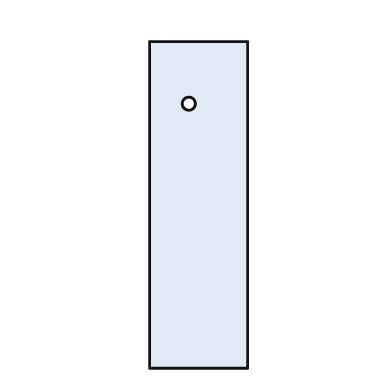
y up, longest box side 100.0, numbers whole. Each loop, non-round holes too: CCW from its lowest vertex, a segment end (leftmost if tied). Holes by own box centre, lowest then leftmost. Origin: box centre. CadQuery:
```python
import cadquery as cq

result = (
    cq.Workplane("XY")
    .moveTo(-15.0, -50.0)
    .lineTo(15.0, -50.0)
    .lineTo(15.0, 50.0)
    .lineTo(-15.0, 50.0)
    .close()
    .moveTo(-3.0, 31.0)
    .circle(2.0)
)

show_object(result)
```